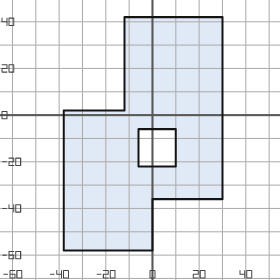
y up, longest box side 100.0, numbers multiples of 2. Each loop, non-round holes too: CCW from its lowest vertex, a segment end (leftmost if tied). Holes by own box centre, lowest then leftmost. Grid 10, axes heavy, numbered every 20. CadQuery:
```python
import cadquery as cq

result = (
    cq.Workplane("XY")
    .moveTo(-38.0, -58.0)
    .lineTo(0.0, -58.0)
    .lineTo(0.0, -36.0)
    .lineTo(30.0, -36.0)
    .lineTo(30.0, 42.0)
    .lineTo(-12.0, 42.0)
    .lineTo(-12.0, 2.0)
    .lineTo(-38.0, 2.0)
    .close()
    .moveTo(-6.0, -22.0)
    .lineTo(10.0, -22.0)
    .lineTo(10.0, -6.0)
    .lineTo(-6.0, -6.0)
    .close()
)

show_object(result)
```